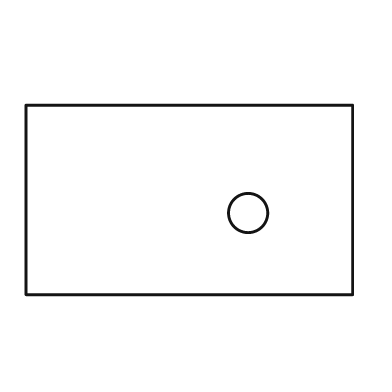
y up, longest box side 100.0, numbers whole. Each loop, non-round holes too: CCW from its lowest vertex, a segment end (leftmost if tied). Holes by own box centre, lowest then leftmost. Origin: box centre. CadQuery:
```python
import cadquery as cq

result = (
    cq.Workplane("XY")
    .moveTo(-50.0, -29.0)
    .lineTo(50.0, -29.0)
    .lineTo(50.0, 29.0)
    .lineTo(-50.0, 29.0)
    .close()
    .moveTo(18.0, -4.0)
    .circle(6.0)
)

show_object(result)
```